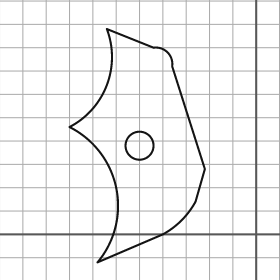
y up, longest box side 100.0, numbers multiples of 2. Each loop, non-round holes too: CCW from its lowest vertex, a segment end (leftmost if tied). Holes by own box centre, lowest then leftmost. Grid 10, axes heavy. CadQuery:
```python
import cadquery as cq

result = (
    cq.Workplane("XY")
    .moveTo(-68.0, -12.0)
    .lineTo(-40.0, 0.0)
    .threePointArc((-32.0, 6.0), (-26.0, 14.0))
    .lineTo(-22.0, 28.0)
    .lineTo(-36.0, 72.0)
    .threePointArc((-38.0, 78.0), (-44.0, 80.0))
    .lineTo(-64.0, 88.0)
    .threePointArc((-64.0, 64.0), (-80.0, 46.0))
    .threePointArc((-60.0, 20.0), (-68.0, -12.0))
    .close()
    .moveTo(-50.0, 38.0)
    .circle(6.0)
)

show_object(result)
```